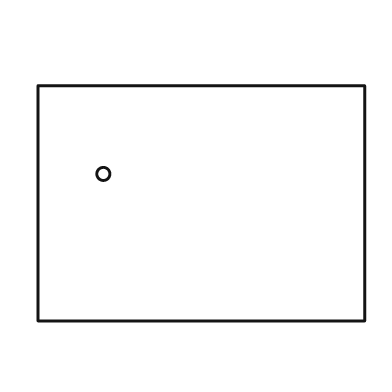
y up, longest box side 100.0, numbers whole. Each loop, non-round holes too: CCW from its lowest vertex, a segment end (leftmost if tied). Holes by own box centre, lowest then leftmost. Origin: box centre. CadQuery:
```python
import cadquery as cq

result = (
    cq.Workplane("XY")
    .moveTo(-50.0, -36.0)
    .lineTo(50.0, -36.0)
    .lineTo(50.0, 36.0)
    .lineTo(-50.0, 36.0)
    .close()
    .moveTo(-30.0, 9.0)
    .circle(2.0)
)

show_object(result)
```